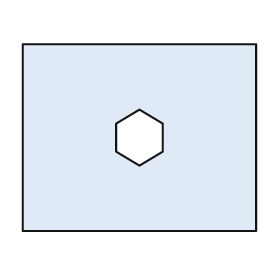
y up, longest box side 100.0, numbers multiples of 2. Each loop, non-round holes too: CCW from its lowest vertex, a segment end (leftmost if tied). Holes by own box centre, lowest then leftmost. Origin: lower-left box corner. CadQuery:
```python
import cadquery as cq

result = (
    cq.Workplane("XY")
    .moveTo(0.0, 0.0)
    .lineTo(100.0, 0.0)
    .lineTo(100.0, 80.0)
    .lineTo(0.0, 80.0)
    .close()
    .moveTo(50.0, 28.0)
    .lineTo(60.0, 34.0)
    .lineTo(60.0, 46.0)
    .lineTo(50.0, 52.0)
    .lineTo(40.0, 46.0)
    .lineTo(40.0, 34.0)
    .close()
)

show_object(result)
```